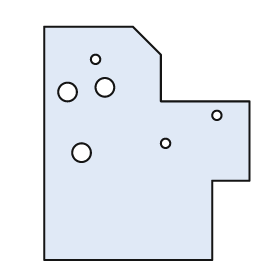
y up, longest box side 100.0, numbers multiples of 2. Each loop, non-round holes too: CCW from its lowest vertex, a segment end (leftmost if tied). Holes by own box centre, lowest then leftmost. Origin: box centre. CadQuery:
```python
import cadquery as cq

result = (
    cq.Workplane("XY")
    .moveTo(-44.0, -50.0)
    .lineTo(28.0, -50.0)
    .lineTo(28.0, -16.0)
    .lineTo(44.0, -16.0)
    .lineTo(44.0, 18.0)
    .lineTo(6.0, 18.0)
    .lineTo(6.0, 38.0)
    .lineTo(-6.0, 50.0)
    .lineTo(-44.0, 50.0)
    .close()
    .moveTo(-28.0, -4.0)
    .circle(4.0)
    .moveTo(8.0, 0.0)
    .circle(2.0)
    .moveTo(30.0, 12.0)
    .circle(2.0)
    .moveTo(-34.0, 22.0)
    .circle(4.0)
    .moveTo(-18.0, 24.0)
    .circle(4.0)
    .moveTo(-22.0, 36.0)
    .circle(2.0)
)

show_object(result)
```